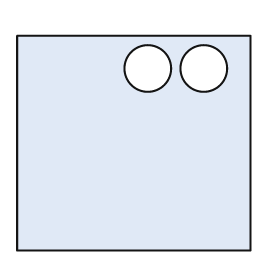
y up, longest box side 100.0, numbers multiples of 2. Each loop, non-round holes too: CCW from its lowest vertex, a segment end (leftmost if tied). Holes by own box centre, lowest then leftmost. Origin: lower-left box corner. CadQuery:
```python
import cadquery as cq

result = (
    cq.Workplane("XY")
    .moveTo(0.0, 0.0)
    .lineTo(100.0, 0.0)
    .lineTo(100.0, 92.0)
    .lineTo(0.0, 92.0)
    .close()
    .moveTo(56.0, 78.0)
    .circle(10.0)
    .moveTo(80.0, 78.0)
    .circle(10.0)
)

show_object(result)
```